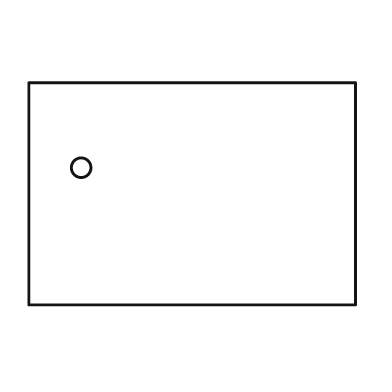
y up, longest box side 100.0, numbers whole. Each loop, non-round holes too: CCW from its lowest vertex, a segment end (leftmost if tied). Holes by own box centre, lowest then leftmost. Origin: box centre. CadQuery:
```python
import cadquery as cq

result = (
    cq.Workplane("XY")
    .moveTo(-50.0, -34.0)
    .lineTo(50.0, -34.0)
    .lineTo(50.0, 34.0)
    .lineTo(-50.0, 34.0)
    .close()
    .moveTo(-34.0, 8.0)
    .circle(3.0)
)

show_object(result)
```